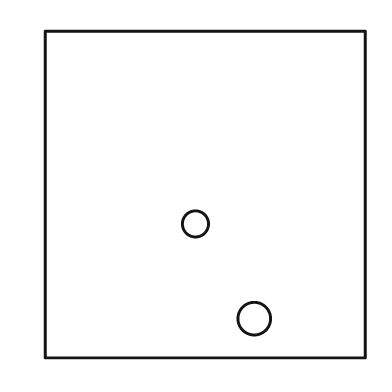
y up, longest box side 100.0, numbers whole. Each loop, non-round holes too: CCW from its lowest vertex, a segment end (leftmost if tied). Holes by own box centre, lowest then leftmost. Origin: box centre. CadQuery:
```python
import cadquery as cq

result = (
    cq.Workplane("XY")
    .moveTo(-49.0, -50.0)
    .lineTo(49.0, -50.0)
    .lineTo(49.0, 50.0)
    .lineTo(-49.0, 50.0)
    .close()
    .moveTo(15.0, -38.0)
    .circle(5.0)
    .moveTo(-3.0, -9.0)
    .circle(4.0)
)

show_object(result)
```